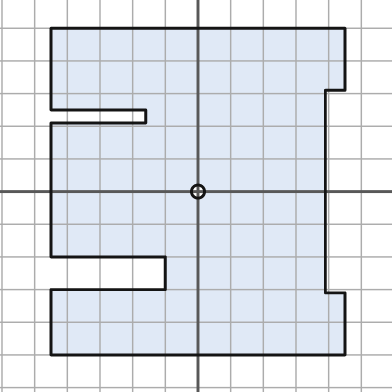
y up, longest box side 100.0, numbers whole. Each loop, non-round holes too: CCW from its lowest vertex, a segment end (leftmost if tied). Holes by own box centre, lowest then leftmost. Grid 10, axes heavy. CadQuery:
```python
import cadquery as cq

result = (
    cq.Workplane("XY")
    .moveTo(-45.0, -50.0)
    .lineTo(45.0, -50.0)
    .lineTo(45.0, -31.0)
    .lineTo(39.0, -31.0)
    .lineTo(39.0, 31.0)
    .lineTo(45.0, 31.0)
    .lineTo(45.0, 50.0)
    .lineTo(-45.0, 50.0)
    .lineTo(-45.0, 25.0)
    .lineTo(-16.0, 25.0)
    .lineTo(-16.0, 21.0)
    .lineTo(-45.0, 21.0)
    .lineTo(-45.0, -20.0)
    .lineTo(-10.0, -20.0)
    .lineTo(-10.0, -30.0)
    .lineTo(-45.0, -30.0)
    .close()
    .moveTo(0.0, 0.0)
    .circle(2.0)
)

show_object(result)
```